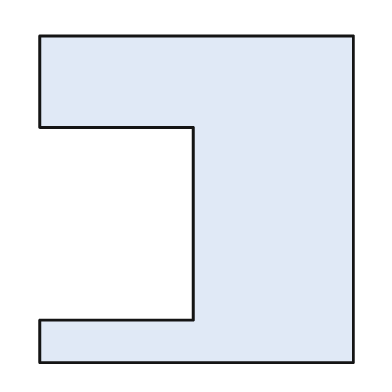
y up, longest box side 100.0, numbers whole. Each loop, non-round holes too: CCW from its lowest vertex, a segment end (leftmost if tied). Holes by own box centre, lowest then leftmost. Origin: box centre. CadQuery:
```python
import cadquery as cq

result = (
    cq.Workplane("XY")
    .moveTo(-48.0, -50.0)
    .lineTo(48.0, -50.0)
    .lineTo(48.0, 50.0)
    .lineTo(-48.0, 50.0)
    .lineTo(-48.0, 22.0)
    .lineTo(-1.0, 22.0)
    .lineTo(-1.0, -37.0)
    .lineTo(-48.0, -37.0)
    .close()
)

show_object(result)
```